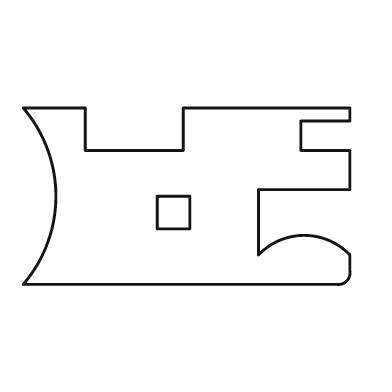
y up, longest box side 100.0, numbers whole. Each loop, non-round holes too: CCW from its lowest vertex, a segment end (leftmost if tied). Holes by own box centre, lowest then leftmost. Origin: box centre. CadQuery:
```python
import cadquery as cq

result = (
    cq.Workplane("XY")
    .moveTo(-50.0, -27.0)
    .lineTo(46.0, -27.0)
    .threePointArc((49.0, -26.0), (50.0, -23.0))
    .lineTo(50.0, -18.0)
    .threePointArc((36.0, -12.0), (22.0, -18.0))
    .lineTo(22.0, 2.0)
    .lineTo(50.0, 2.0)
    .lineTo(50.0, 14.0)
    .lineTo(35.0, 14.0)
    .lineTo(35.0, 23.0)
    .lineTo(50.0, 23.0)
    .lineTo(50.0, 27.0)
    .lineTo(-1.0, 27.0)
    .lineTo(-1.0, 14.0)
    .lineTo(-31.0, 14.0)
    .lineTo(-31.0, 27.0)
    .lineTo(-50.0, 27.0)
    .threePointArc((-40.0, 0.0), (-50.0, -27.0))
    .close()
    .moveTo(-9.0, -10.0)
    .lineTo(1.0, -10.0)
    .lineTo(1.0, 0.0)
    .lineTo(-9.0, 0.0)
    .close()
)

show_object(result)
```